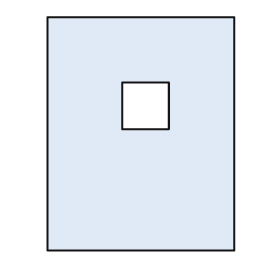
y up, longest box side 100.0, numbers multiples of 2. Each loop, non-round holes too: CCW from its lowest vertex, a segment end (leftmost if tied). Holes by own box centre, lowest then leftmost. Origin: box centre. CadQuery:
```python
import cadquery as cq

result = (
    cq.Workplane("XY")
    .moveTo(-40.0, -50.0)
    .lineTo(40.0, -50.0)
    .lineTo(40.0, 50.0)
    .lineTo(-40.0, 50.0)
    .close()
    .moveTo(-8.0, 2.0)
    .lineTo(12.0, 2.0)
    .lineTo(12.0, 22.0)
    .lineTo(-8.0, 22.0)
    .close()
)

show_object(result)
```